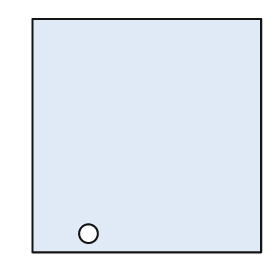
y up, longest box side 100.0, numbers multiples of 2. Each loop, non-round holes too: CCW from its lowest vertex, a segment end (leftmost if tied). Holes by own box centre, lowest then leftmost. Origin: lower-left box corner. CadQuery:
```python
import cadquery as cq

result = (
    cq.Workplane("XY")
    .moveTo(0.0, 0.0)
    .lineTo(98.0, 0.0)
    .lineTo(98.0, 100.0)
    .lineTo(0.0, 100.0)
    .close()
    .moveTo(24.0, 8.0)
    .circle(4.0)
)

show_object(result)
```